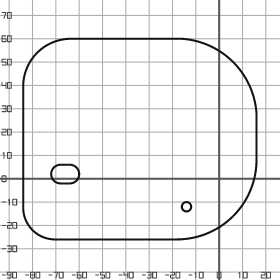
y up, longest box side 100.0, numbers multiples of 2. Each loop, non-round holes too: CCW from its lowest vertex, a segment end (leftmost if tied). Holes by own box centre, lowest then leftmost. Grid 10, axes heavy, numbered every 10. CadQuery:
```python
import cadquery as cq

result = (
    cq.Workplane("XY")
    .moveTo(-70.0, -26.0)
    .lineTo(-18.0, -26.0)
    .threePointArc((6.0, -16.0), (16.0, 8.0))
    .lineTo(16.0, 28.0)
    .threePointArc((6.0, 50.0), (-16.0, 60.0))
    .lineTo(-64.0, 60.0)
    .threePointArc((-78.0, 54.0), (-84.0, 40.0))
    .lineTo(-84.0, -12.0)
    .threePointArc((-80.0, -22.0), (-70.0, -26.0))
    .close()
    .moveTo(-14.0, -12.0)
    .circle(2.0)
    .moveTo(-68.0, -2.0)
    .lineTo(-64.0, -2.0)
    .threePointArc((-60.0, 2.0), (-64.0, 6.0))
    .lineTo(-68.0, 6.0)
    .threePointArc((-72.0, 2.0), (-68.0, -2.0))
    .close()
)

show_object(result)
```